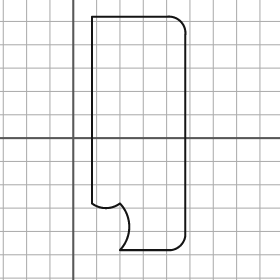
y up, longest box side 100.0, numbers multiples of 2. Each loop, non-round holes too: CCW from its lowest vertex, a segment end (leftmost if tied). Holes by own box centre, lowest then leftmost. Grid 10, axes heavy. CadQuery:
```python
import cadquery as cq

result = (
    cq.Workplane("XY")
    .moveTo(20.0, -48.0)
    .lineTo(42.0, -48.0)
    .threePointArc((46.0, -46.0), (48.0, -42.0))
    .lineTo(48.0, 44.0)
    .threePointArc((46.0, 50.0), (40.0, 52.0))
    .lineTo(8.0, 52.0)
    .lineTo(8.0, -28.0)
    .threePointArc((14.0, -30.0), (20.0, -28.0))
    .threePointArc((24.0, -38.0), (20.0, -48.0))
    .close()
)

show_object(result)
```